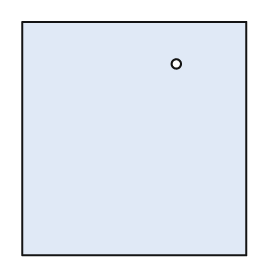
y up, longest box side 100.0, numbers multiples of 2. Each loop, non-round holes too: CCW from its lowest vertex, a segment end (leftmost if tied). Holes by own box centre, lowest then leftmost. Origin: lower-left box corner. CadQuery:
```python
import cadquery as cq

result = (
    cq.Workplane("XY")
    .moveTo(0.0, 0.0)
    .lineTo(96.0, 0.0)
    .lineTo(96.0, 100.0)
    .lineTo(0.0, 100.0)
    .close()
    .moveTo(66.0, 82.0)
    .circle(2.0)
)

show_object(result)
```